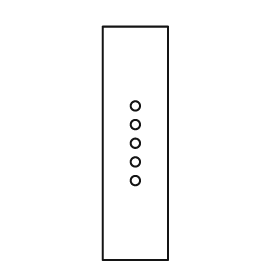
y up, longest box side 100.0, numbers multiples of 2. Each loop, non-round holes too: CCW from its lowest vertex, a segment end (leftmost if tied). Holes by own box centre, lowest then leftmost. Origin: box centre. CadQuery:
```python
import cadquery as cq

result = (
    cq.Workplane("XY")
    .moveTo(-14.0, -50.0)
    .lineTo(14.0, -50.0)
    .lineTo(14.0, 50.0)
    .lineTo(-14.0, 50.0)
    .close()
    .moveTo(0.0, -16.0)
    .circle(2.0)
    .moveTo(0.0, -8.0)
    .circle(2.0)
    .moveTo(0.0, 0.0)
    .circle(2.0)
    .moveTo(0.0, 8.0)
    .circle(2.0)
    .moveTo(0.0, 16.0)
    .circle(2.0)
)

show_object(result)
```